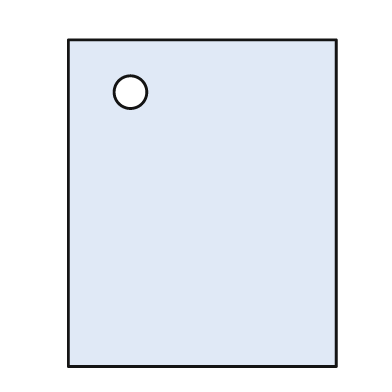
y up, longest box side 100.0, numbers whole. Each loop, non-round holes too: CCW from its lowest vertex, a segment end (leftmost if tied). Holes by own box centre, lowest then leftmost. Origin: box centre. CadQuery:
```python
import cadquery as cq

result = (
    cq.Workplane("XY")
    .moveTo(-41.0, -50.0)
    .lineTo(41.0, -50.0)
    .lineTo(41.0, 50.0)
    .lineTo(-41.0, 50.0)
    .close()
    .moveTo(-22.0, 34.0)
    .circle(5.0)
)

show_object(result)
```